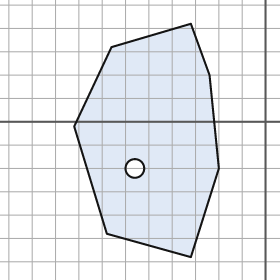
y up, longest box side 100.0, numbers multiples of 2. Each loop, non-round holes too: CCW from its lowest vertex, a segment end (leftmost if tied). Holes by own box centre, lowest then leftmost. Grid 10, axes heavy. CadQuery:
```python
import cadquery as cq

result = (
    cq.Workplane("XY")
    .moveTo(-32.0, -58.0)
    .lineTo(-20.0, -20.0)
    .lineTo(-24.0, 20.0)
    .lineTo(-32.0, 42.0)
    .lineTo(-66.0, 32.0)
    .lineTo(-82.0, -2.0)
    .lineTo(-68.0, -48.0)
    .close()
    .moveTo(-56.0, -20.0)
    .circle(4.0)
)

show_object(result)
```